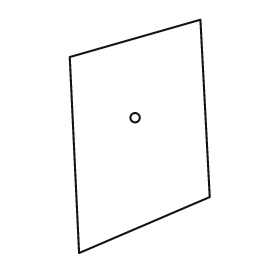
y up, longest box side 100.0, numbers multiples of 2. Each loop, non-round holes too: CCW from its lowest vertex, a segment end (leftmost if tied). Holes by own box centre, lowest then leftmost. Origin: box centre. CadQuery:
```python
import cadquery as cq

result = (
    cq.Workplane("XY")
    .moveTo(-26.0, -50.0)
    .lineTo(30.0, -26.0)
    .lineTo(26.0, 50.0)
    .lineTo(-30.0, 34.0)
    .close()
    .moveTo(-2.0, 8.0)
    .circle(2.0)
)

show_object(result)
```